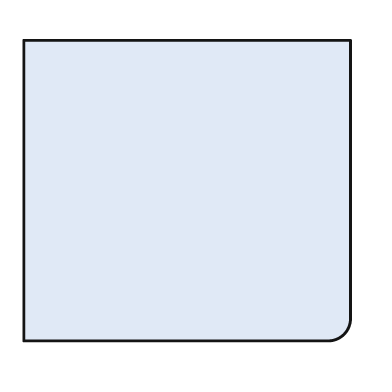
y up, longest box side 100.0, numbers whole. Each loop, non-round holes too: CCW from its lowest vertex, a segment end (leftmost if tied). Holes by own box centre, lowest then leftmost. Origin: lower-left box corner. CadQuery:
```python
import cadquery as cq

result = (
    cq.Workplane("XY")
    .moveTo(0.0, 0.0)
    .lineTo(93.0, 0.0)
    .threePointArc((98.0, 2.0), (100.0, 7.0))
    .lineTo(100.0, 92.0)
    .lineTo(0.0, 92.0)
    .close()
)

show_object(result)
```